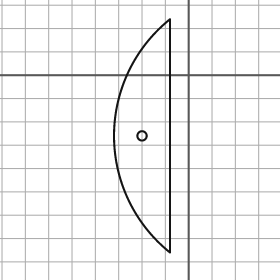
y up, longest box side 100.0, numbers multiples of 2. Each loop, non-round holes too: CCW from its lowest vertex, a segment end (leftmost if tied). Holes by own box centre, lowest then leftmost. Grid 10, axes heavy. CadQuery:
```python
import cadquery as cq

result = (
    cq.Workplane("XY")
    .moveTo(-8.0, -76.0)
    .lineTo(-8.0, 24.0)
    .threePointArc((-32.0, -26.0), (-8.0, -76.0))
    .close()
    .moveTo(-20.0, -26.0)
    .circle(2.0)
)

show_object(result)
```